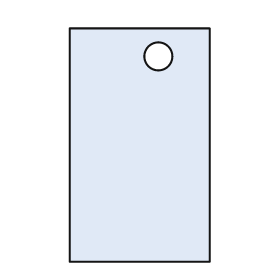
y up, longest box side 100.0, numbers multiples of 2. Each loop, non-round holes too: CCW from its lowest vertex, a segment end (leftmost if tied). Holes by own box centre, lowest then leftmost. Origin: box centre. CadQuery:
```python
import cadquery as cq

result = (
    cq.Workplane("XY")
    .moveTo(-30.0, -50.0)
    .lineTo(30.0, -50.0)
    .lineTo(30.0, 50.0)
    .lineTo(-30.0, 50.0)
    .close()
    .moveTo(8.0, 38.0)
    .circle(6.0)
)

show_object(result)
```